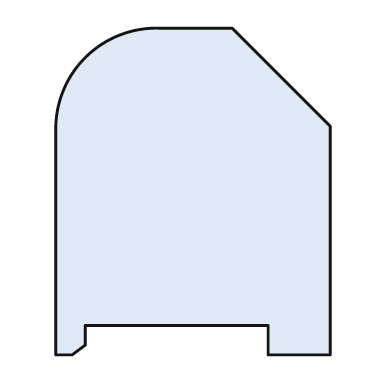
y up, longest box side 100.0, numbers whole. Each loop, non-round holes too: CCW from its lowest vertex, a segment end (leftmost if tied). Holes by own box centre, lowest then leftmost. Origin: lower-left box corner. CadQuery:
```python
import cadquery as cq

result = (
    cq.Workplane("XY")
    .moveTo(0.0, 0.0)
    .lineTo(5.0, 0.0)
    .lineTo(9.0, 3.0)
    .lineTo(9.0, 9.0)
    .lineTo(65.0, 9.0)
    .lineTo(65.0, 0.0)
    .lineTo(84.0, 0.0)
    .lineTo(84.0, 70.0)
    .lineTo(54.0, 100.0)
    .lineTo(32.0, 100.0)
    .threePointArc((9.0, 91.0), (0.0, 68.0))
    .close()
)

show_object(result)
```